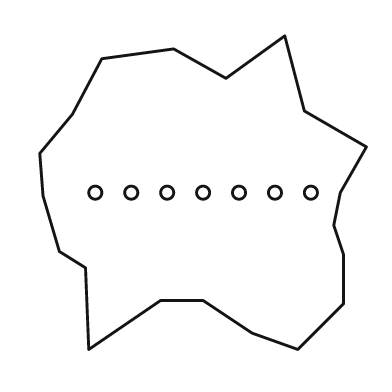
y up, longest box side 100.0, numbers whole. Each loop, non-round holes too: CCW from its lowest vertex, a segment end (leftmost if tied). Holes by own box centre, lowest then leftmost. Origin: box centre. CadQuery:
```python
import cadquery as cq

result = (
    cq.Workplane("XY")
    .moveTo(-35.0, -48.0)
    .lineTo(-13.0, -33.0)
    .lineTo(0.0, -33.0)
    .lineTo(15.0, -43.0)
    .lineTo(29.0, -48.0)
    .lineTo(43.0, -34.0)
    .lineTo(43.0, -19.0)
    .lineTo(40.0, -10.0)
    .lineTo(42.0, 0.0)
    .lineTo(50.0, 14.0)
    .lineTo(31.0, 25.0)
    .lineTo(25.0, 48.0)
    .lineTo(7.0, 35.0)
    .lineTo(-9.0, 44.0)
    .lineTo(-31.0, 41.0)
    .lineTo(-40.0, 24.0)
    .lineTo(-50.0, 12.0)
    .lineTo(-49.0, -1.0)
    .lineTo(-44.0, -18.0)
    .lineTo(-36.0, -23.0)
    .close()
    .moveTo(-33.0, 0.0)
    .circle(2.0)
    .moveTo(-22.0, 0.0)
    .circle(2.0)
    .moveTo(-11.0, 0.0)
    .circle(2.0)
    .moveTo(0.0, 0.0)
    .circle(2.0)
    .moveTo(11.0, 0.0)
    .circle(2.0)
    .moveTo(22.0, 0.0)
    .circle(2.0)
    .moveTo(33.0, 0.0)
    .circle(2.0)
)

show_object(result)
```